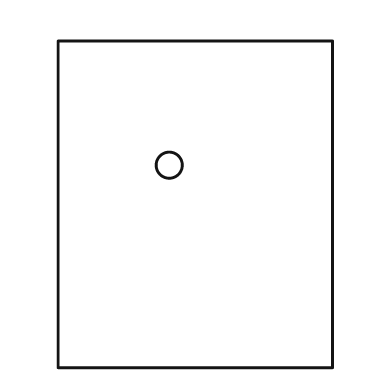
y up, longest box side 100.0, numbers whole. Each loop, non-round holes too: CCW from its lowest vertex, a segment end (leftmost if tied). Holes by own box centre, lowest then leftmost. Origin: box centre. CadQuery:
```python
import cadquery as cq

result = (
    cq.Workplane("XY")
    .moveTo(-42.0, -50.0)
    .lineTo(42.0, -50.0)
    .lineTo(42.0, 50.0)
    .lineTo(-42.0, 50.0)
    .close()
    .moveTo(-8.0, 12.0)
    .circle(4.0)
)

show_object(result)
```